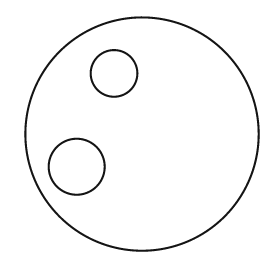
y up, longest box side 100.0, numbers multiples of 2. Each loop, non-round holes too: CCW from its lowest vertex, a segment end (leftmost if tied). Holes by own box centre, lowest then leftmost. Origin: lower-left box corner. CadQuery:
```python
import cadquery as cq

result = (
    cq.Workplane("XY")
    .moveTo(50.0, 50.0)
    .circle(50.0)
    .moveTo(22.0, 36.0)
    .circle(12.0)
    .moveTo(38.0, 76.0)
    .circle(10.0)
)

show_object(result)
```